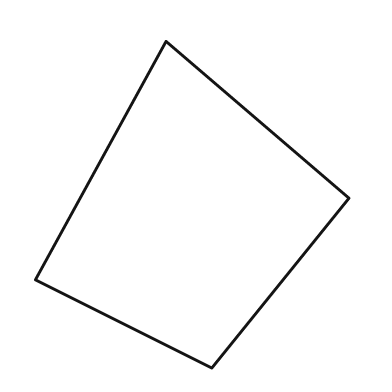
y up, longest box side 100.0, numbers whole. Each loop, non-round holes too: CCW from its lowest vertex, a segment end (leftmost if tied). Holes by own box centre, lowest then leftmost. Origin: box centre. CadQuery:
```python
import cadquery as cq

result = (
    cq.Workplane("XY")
    .moveTo(6.0, -50.0)
    .lineTo(48.0, 2.0)
    .lineTo(-8.0, 50.0)
    .lineTo(-48.0, -23.0)
    .close()
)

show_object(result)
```